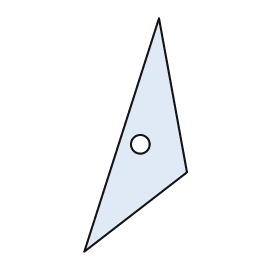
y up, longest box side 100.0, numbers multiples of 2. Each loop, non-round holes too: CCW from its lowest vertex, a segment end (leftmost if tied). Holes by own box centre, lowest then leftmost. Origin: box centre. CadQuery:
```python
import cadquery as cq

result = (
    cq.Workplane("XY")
    .moveTo(-22.0, -50.0)
    .lineTo(22.0, -16.0)
    .lineTo(10.0, 50.0)
    .close()
    .moveTo(2.0, -4.0)
    .circle(4.0)
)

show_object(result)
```